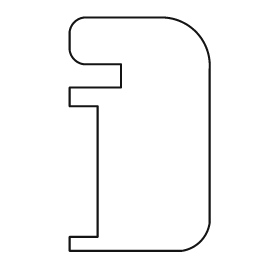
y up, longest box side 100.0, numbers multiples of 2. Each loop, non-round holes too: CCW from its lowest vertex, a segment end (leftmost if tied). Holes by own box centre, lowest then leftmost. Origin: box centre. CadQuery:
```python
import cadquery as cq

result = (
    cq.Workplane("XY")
    .moveTo(-30.0, -50.0)
    .lineTo(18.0, -50.0)
    .threePointArc((26.0, -46.0), (30.0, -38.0))
    .lineTo(30.0, 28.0)
    .threePointArc((24.0, 44.0), (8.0, 50.0))
    .lineTo(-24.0, 50.0)
    .threePointArc((-28.0, 48.0), (-30.0, 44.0))
    .lineTo(-30.0, 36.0)
    .threePointArc((-28.0, 32.0), (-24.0, 30.0))
    .lineTo(-8.0, 30.0)
    .lineTo(-8.0, 20.0)
    .lineTo(-30.0, 20.0)
    .lineTo(-30.0, 12.0)
    .lineTo(-18.0, 12.0)
    .lineTo(-18.0, -44.0)
    .lineTo(-30.0, -44.0)
    .close()
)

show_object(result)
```